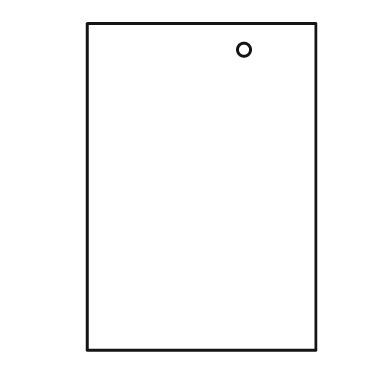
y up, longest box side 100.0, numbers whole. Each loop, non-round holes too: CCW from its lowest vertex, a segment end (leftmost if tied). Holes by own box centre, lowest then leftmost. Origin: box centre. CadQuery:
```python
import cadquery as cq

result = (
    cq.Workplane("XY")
    .moveTo(-35.0, -50.0)
    .lineTo(35.0, -50.0)
    .lineTo(35.0, 50.0)
    .lineTo(-35.0, 50.0)
    .close()
    .moveTo(13.0, 42.0)
    .circle(2.0)
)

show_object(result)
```